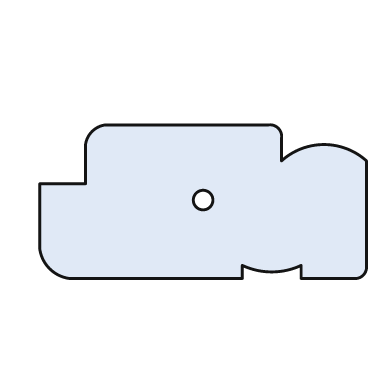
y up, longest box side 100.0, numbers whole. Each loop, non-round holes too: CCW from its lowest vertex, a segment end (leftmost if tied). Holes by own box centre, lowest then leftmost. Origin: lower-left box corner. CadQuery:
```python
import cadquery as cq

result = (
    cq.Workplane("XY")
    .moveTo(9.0, 0.0)
    .lineTo(62.0, 0.0)
    .lineTo(62.0, 4.0)
    .threePointArc((71.0, 2.0), (80.0, 4.0))
    .lineTo(80.0, 0.0)
    .lineTo(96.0, 0.0)
    .threePointArc((99.0, 1.0), (100.0, 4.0))
    .lineTo(100.0, 36.0)
    .threePointArc((87.0, 41.0), (74.0, 36.0))
    .lineTo(74.0, 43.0)
    .threePointArc((73.0, 46.0), (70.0, 47.0))
    .lineTo(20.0, 47.0)
    .threePointArc((16.0, 45.0), (14.0, 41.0))
    .lineTo(14.0, 29.0)
    .lineTo(0.0, 29.0)
    .lineTo(0.0, 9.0)
    .threePointArc((3.0, 3.0), (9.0, 0.0))
    .close()
    .moveTo(50.0, 24.0)
    .circle(3.0)
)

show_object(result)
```